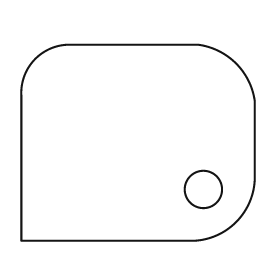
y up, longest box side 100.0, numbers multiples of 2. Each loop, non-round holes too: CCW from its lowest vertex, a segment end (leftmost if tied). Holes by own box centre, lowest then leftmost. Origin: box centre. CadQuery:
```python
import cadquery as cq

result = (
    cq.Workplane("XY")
    .moveTo(-50.0, -42.0)
    .lineTo(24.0, -42.0)
    .threePointArc((42.0, -34.0), (50.0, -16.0))
    .lineTo(50.0, 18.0)
    .threePointArc((42.0, 34.0), (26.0, 42.0))
    .lineTo(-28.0, 42.0)
    .threePointArc((-44.0, 36.0), (-50.0, 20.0))
    .close()
    .moveTo(28.0, -20.0)
    .circle(8.0)
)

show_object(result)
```